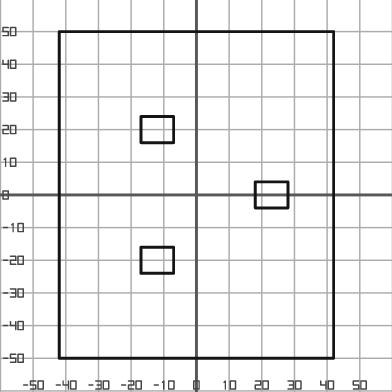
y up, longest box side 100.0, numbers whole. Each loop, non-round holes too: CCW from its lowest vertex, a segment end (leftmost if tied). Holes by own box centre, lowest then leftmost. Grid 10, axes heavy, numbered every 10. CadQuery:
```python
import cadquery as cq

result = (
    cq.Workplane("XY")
    .moveTo(-42.0, -50.0)
    .lineTo(42.0, -50.0)
    .lineTo(42.0, 50.0)
    .lineTo(-42.0, 50.0)
    .close()
    .moveTo(-17.0, -24.0)
    .lineTo(-7.0, -24.0)
    .lineTo(-7.0, -16.0)
    .lineTo(-17.0, -16.0)
    .close()
    .moveTo(18.0, -4.0)
    .lineTo(28.0, -4.0)
    .lineTo(28.0, 4.0)
    .lineTo(18.0, 4.0)
    .close()
    .moveTo(-17.0, 16.0)
    .lineTo(-7.0, 16.0)
    .lineTo(-7.0, 24.0)
    .lineTo(-17.0, 24.0)
    .close()
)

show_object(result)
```